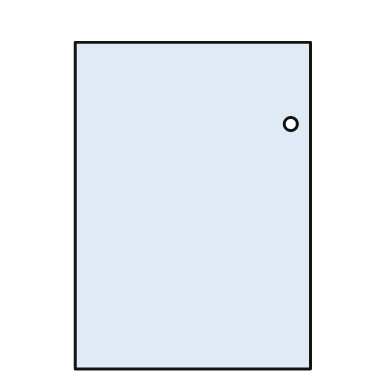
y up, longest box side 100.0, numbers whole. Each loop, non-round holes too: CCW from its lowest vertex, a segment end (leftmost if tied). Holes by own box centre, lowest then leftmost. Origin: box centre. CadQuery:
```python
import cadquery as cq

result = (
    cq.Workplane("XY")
    .moveTo(-36.0, -50.0)
    .lineTo(36.0, -50.0)
    .lineTo(36.0, 50.0)
    .lineTo(-36.0, 50.0)
    .close()
    .moveTo(30.0, 25.0)
    .circle(2.0)
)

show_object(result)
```